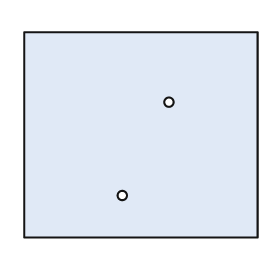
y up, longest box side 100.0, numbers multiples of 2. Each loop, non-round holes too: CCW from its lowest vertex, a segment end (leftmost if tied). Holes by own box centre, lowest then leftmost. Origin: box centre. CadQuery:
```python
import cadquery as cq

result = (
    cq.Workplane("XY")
    .moveTo(-50.0, -44.0)
    .lineTo(50.0, -44.0)
    .lineTo(50.0, 44.0)
    .lineTo(-50.0, 44.0)
    .close()
    .moveTo(-8.0, -26.0)
    .circle(2.0)
    .moveTo(12.0, 14.0)
    .circle(2.0)
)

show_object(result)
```